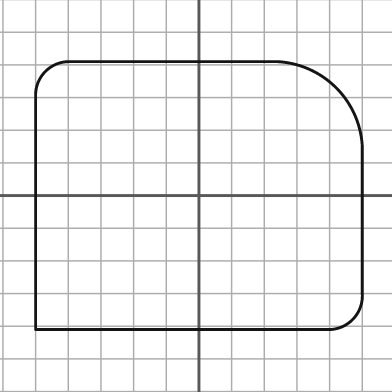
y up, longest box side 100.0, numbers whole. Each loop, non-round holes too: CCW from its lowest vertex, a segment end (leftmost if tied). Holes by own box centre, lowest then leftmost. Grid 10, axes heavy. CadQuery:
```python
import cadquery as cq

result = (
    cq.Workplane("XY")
    .moveTo(-50.0, -41.0)
    .lineTo(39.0, -41.0)
    .threePointArc((47.0, -38.0), (50.0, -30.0))
    .lineTo(50.0, 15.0)
    .threePointArc((42.0, 33.0), (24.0, 41.0))
    .lineTo(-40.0, 41.0)
    .threePointArc((-47.0, 38.0), (-50.0, 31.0))
    .close()
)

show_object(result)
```